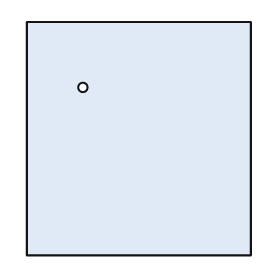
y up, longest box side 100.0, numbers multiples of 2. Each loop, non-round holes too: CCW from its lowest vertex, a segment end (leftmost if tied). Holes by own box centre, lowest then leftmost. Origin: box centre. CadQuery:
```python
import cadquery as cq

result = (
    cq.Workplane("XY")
    .moveTo(-48.0, -50.0)
    .lineTo(48.0, -50.0)
    .lineTo(48.0, 50.0)
    .lineTo(-48.0, 50.0)
    .close()
    .moveTo(-24.0, 22.0)
    .circle(2.0)
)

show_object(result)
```